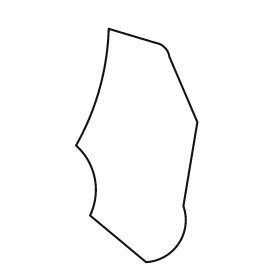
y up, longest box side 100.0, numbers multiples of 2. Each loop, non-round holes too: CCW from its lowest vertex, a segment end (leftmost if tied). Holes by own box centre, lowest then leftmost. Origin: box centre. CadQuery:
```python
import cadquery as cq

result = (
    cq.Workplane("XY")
    .moveTo(4.0, -50.0)
    .threePointArc((18.0, -42.0), (20.0, -26.0))
    .lineTo(26.0, 10.0)
    .lineTo(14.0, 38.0)
    .threePointArc((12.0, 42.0), (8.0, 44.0))
    .lineTo(-12.0, 50.0)
    .threePointArc((-16.0, 24.0), (-26.0, 0.0))
    .threePointArc((-18.0, -14.0), (-20.0, -30.0))
    .close()
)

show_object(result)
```